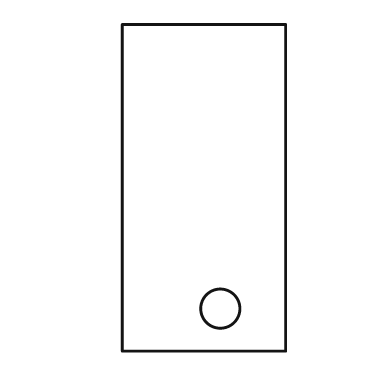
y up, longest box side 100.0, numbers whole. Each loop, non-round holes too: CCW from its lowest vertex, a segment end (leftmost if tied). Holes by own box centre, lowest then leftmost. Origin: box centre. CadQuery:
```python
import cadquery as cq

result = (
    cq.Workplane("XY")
    .moveTo(-25.0, -50.0)
    .lineTo(25.0, -50.0)
    .lineTo(25.0, 50.0)
    .lineTo(-25.0, 50.0)
    .close()
    .moveTo(5.0, -37.0)
    .circle(6.0)
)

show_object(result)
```